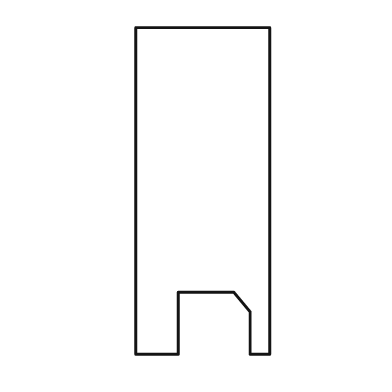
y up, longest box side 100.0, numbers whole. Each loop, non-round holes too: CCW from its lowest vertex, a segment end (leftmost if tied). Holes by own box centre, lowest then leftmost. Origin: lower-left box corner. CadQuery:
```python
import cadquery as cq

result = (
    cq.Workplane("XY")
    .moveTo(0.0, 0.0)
    .lineTo(13.0, 0.0)
    .lineTo(13.0, 19.0)
    .lineTo(30.0, 19.0)
    .lineTo(35.0, 13.0)
    .lineTo(35.0, 0.0)
    .lineTo(41.0, 0.0)
    .lineTo(41.0, 100.0)
    .lineTo(0.0, 100.0)
    .close()
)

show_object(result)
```